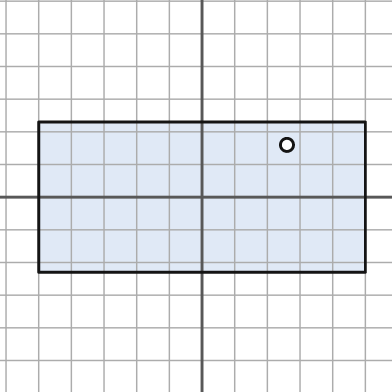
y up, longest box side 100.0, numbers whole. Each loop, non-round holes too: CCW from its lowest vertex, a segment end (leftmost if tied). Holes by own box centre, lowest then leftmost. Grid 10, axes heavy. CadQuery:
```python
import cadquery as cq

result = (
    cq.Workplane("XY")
    .moveTo(-50.0, -23.0)
    .lineTo(50.0, -23.0)
    .lineTo(50.0, 23.0)
    .lineTo(-50.0, 23.0)
    .close()
    .moveTo(26.0, 16.0)
    .circle(2.0)
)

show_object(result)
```